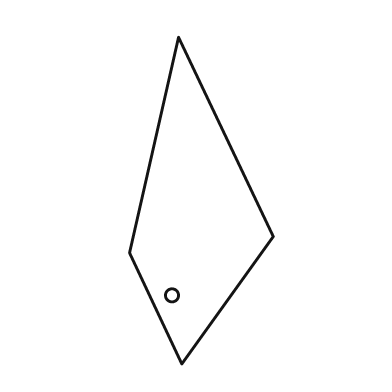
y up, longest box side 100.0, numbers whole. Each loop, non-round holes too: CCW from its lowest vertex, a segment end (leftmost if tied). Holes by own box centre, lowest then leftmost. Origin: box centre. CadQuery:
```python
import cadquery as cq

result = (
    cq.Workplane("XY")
    .moveTo(-6.0, -50.0)
    .lineTo(22.0, -11.0)
    .lineTo(-7.0, 50.0)
    .lineTo(-22.0, -16.0)
    .close()
    .moveTo(-9.0, -29.0)
    .circle(2.0)
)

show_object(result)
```